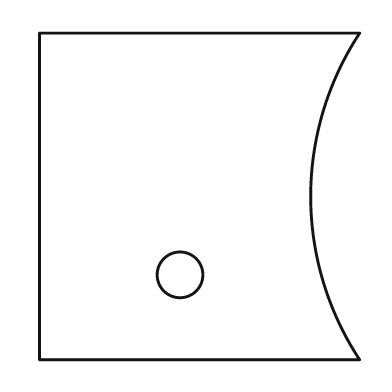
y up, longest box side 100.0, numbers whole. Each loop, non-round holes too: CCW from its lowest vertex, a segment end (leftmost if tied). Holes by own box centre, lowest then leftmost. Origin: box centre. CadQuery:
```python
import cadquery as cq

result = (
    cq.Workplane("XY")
    .moveTo(-49.0, -50.0)
    .lineTo(49.0, -50.0)
    .threePointArc((34.0, 0.0), (49.0, 50.0))
    .lineTo(-49.0, 50.0)
    .close()
    .moveTo(-6.0, -24.0)
    .circle(7.0)
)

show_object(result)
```